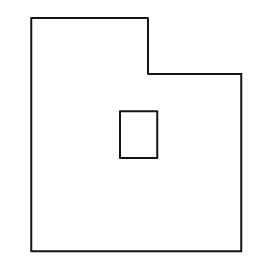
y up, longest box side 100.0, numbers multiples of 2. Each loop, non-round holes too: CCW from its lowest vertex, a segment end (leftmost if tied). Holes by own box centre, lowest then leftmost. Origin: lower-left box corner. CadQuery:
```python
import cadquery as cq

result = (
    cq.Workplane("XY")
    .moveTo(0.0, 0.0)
    .lineTo(90.0, 0.0)
    .lineTo(90.0, 76.0)
    .lineTo(50.0, 76.0)
    .lineTo(50.0, 100.0)
    .lineTo(0.0, 100.0)
    .close()
    .moveTo(38.0, 40.0)
    .lineTo(54.0, 40.0)
    .lineTo(54.0, 60.0)
    .lineTo(38.0, 60.0)
    .close()
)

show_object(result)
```